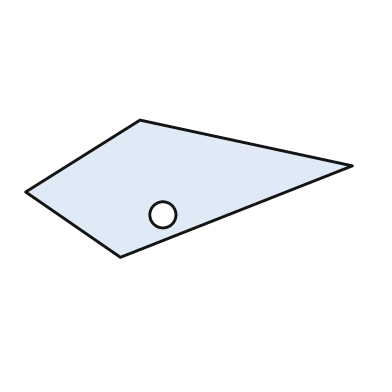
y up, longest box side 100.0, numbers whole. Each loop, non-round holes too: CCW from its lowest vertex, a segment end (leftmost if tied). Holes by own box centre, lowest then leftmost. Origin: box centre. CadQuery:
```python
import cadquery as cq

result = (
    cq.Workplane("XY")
    .moveTo(-21.0, -21.0)
    .lineTo(50.0, 7.0)
    .lineTo(-15.0, 21.0)
    .lineTo(-50.0, -1.0)
    .close()
    .moveTo(-8.0, -8.0)
    .circle(4.0)
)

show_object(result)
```